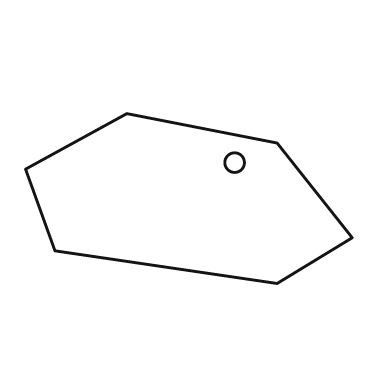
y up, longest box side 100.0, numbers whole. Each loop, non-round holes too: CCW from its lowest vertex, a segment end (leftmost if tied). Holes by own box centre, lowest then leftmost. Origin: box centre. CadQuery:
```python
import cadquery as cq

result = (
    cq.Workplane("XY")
    .moveTo(27.0, -26.0)
    .lineTo(50.0, -12.0)
    .lineTo(27.0, 17.0)
    .lineTo(-19.0, 26.0)
    .lineTo(-50.0, 9.0)
    .lineTo(-41.0, -16.0)
    .close()
    .moveTo(14.0, 11.0)
    .circle(3.0)
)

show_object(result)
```